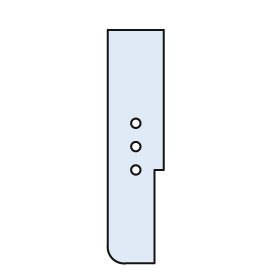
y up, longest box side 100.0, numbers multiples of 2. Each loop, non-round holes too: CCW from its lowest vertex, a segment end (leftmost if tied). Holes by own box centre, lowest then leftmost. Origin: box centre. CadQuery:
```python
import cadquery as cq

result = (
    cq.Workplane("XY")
    .moveTo(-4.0, -50.0)
    .lineTo(8.0, -50.0)
    .lineTo(8.0, -10.0)
    .lineTo(12.0, -10.0)
    .lineTo(12.0, 50.0)
    .lineTo(-12.0, 50.0)
    .lineTo(-12.0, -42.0)
    .threePointArc((-10.0, -48.0), (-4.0, -50.0))
    .close()
    .moveTo(0.0, -10.0)
    .circle(2.0)
    .moveTo(0.0, 0.0)
    .circle(2.0)
    .moveTo(0.0, 10.0)
    .circle(2.0)
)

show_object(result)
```